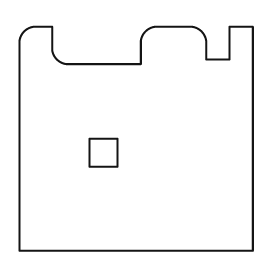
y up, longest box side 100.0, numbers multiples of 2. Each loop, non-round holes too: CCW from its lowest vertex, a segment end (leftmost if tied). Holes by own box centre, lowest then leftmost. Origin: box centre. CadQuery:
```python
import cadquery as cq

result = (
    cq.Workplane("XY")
    .moveTo(-50.0, -48.0)
    .lineTo(50.0, -48.0)
    .lineTo(50.0, 48.0)
    .lineTo(40.0, 48.0)
    .lineTo(40.0, 34.0)
    .lineTo(30.0, 34.0)
    .lineTo(30.0, 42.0)
    .threePointArc((28.0, 46.0), (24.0, 48.0))
    .lineTo(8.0, 48.0)
    .threePointArc((4.0, 46.0), (2.0, 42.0))
    .lineTo(2.0, 32.0)
    .lineTo(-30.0, 32.0)
    .threePointArc((-34.0, 34.0), (-36.0, 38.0))
    .lineTo(-36.0, 48.0)
    .lineTo(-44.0, 48.0)
    .threePointArc((-48.0, 46.0), (-50.0, 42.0))
    .close()
    .moveTo(-20.0, -12.0)
    .lineTo(-8.0, -12.0)
    .lineTo(-8.0, 0.0)
    .lineTo(-20.0, 0.0)
    .close()
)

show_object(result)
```